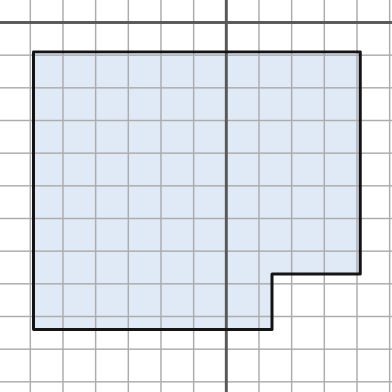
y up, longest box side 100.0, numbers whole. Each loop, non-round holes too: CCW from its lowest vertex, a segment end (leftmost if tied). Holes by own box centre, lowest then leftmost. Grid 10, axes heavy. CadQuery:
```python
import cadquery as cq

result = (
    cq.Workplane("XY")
    .moveTo(-59.0, -94.0)
    .lineTo(14.0, -94.0)
    .lineTo(14.0, -77.0)
    .lineTo(41.0, -77.0)
    .lineTo(41.0, -9.0)
    .lineTo(-59.0, -9.0)
    .close()
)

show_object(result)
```